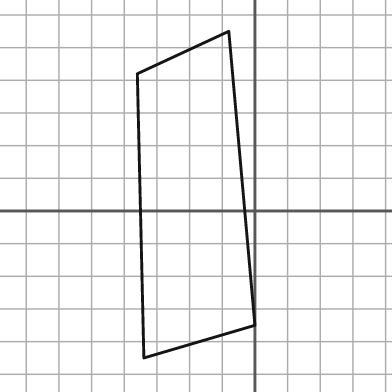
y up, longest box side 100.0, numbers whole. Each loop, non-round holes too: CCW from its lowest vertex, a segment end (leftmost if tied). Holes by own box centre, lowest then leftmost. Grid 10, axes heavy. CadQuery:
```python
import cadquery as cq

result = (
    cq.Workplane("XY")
    .moveTo(-34.0, -45.0)
    .lineTo(0.0, -35.0)
    .lineTo(-8.0, 55.0)
    .lineTo(-36.0, 42.0)
    .close()
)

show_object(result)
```